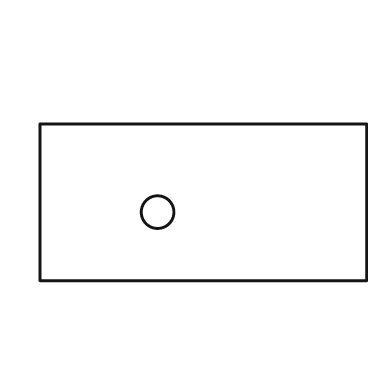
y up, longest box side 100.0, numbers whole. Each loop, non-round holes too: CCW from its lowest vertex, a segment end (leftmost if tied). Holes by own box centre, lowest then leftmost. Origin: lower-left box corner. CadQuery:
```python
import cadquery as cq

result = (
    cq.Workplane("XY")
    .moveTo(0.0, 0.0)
    .lineTo(100.0, 0.0)
    .lineTo(100.0, 48.0)
    .lineTo(0.0, 48.0)
    .close()
    .moveTo(36.0, 21.0)
    .circle(5.0)
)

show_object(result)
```